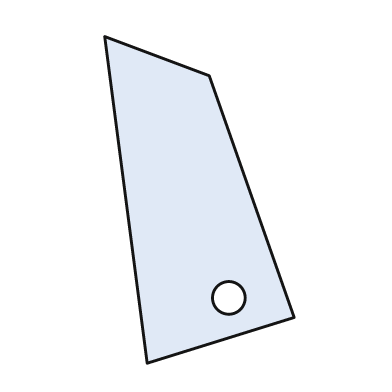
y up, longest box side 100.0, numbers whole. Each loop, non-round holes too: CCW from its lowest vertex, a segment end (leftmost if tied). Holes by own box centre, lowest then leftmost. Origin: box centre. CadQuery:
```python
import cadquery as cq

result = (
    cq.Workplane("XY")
    .moveTo(-16.0, -50.0)
    .lineTo(29.0, -36.0)
    .lineTo(3.0, 38.0)
    .lineTo(-29.0, 50.0)
    .close()
    .moveTo(9.0, -30.0)
    .circle(5.0)
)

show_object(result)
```